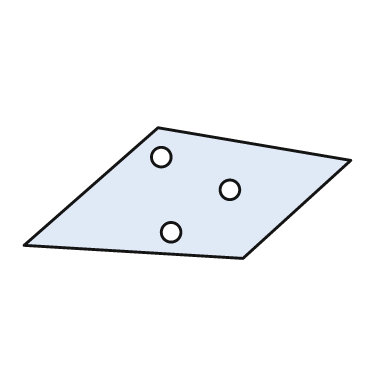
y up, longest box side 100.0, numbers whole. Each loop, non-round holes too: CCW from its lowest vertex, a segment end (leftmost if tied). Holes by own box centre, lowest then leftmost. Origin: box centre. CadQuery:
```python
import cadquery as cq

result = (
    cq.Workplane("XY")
    .moveTo(17.0, -20.0)
    .lineTo(50.0, 10.0)
    .lineTo(-9.0, 20.0)
    .lineTo(-50.0, -16.0)
    .close()
    .moveTo(-5.0, -12.0)
    .circle(3.0)
    .moveTo(13.0, 1.0)
    .circle(3.0)
    .moveTo(-8.0, 11.0)
    .circle(3.0)
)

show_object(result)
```